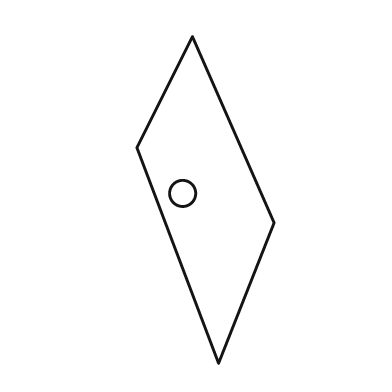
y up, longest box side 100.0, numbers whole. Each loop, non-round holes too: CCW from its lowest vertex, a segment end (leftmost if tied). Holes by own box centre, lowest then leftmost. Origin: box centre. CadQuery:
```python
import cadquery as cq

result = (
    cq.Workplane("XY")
    .moveTo(4.0, -50.0)
    .lineTo(21.0, -7.0)
    .lineTo(-4.0, 50.0)
    .lineTo(-21.0, 16.0)
    .close()
    .moveTo(-7.0, 2.0)
    .circle(4.0)
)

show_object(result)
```